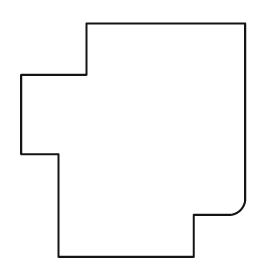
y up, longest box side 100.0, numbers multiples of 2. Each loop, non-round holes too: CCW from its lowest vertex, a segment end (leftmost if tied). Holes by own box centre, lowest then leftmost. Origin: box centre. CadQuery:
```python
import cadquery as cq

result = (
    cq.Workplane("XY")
    .moveTo(-32.0, -50.0)
    .lineTo(26.0, -50.0)
    .lineTo(26.0, -32.0)
    .lineTo(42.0, -32.0)
    .threePointArc((46.0, -30.0), (48.0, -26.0))
    .lineTo(48.0, 50.0)
    .lineTo(-20.0, 50.0)
    .lineTo(-20.0, 28.0)
    .lineTo(-48.0, 28.0)
    .lineTo(-48.0, -6.0)
    .lineTo(-32.0, -6.0)
    .close()
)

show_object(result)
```